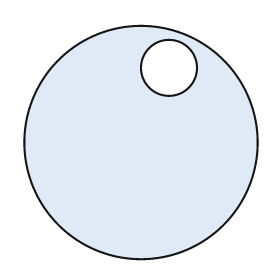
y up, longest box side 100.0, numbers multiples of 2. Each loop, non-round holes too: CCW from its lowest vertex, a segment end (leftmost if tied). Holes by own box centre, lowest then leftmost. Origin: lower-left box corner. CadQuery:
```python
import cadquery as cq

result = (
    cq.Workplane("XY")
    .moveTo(50.0, 50.0)
    .circle(50.0)
    .moveTo(62.0, 82.0)
    .circle(12.0)
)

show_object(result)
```